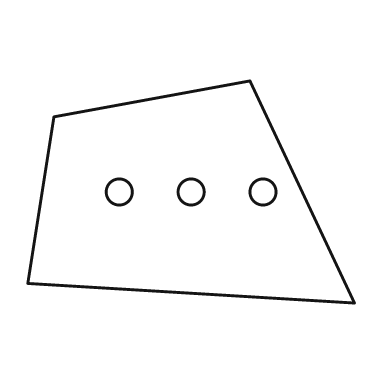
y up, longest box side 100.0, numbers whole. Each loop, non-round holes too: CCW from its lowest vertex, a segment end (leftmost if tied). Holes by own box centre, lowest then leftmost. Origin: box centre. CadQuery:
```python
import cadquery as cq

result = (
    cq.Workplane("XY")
    .moveTo(50.0, -34.0)
    .lineTo(18.0, 34.0)
    .lineTo(-42.0, 23.0)
    .lineTo(-50.0, -28.0)
    .close()
    .moveTo(-22.0, 0.0)
    .circle(4.0)
    .moveTo(0.0, 0.0)
    .circle(4.0)
    .moveTo(22.0, 0.0)
    .circle(4.0)
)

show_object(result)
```